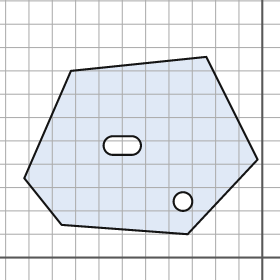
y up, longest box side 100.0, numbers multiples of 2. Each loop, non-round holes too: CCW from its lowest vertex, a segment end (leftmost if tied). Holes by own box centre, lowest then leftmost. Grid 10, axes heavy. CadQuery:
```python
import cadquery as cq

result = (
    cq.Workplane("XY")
    .moveTo(-32.0, 10.0)
    .lineTo(-2.0, 42.0)
    .lineTo(-24.0, 86.0)
    .lineTo(-82.0, 80.0)
    .lineTo(-102.0, 34.0)
    .lineTo(-86.0, 14.0)
    .close()
    .moveTo(-34.0, 24.0)
    .circle(4.0)
    .moveTo(-64.0, 44.0)
    .lineTo(-56.0, 44.0)
    .threePointArc((-52.0, 48.0), (-56.0, 52.0))
    .lineTo(-64.0, 52.0)
    .threePointArc((-68.0, 48.0), (-64.0, 44.0))
    .close()
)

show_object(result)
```